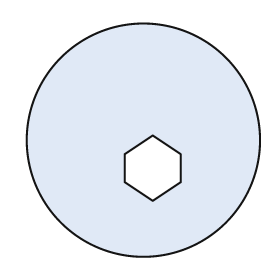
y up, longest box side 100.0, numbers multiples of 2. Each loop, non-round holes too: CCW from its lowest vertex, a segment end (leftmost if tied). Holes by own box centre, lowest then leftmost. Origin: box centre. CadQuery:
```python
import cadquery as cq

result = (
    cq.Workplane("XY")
    .moveTo(0.0, 0.0)
    .circle(50.0)
    .moveTo(4.0, -26.0)
    .lineTo(16.0, -18.0)
    .lineTo(16.0, -6.0)
    .lineTo(4.0, 2.0)
    .lineTo(-8.0, -6.0)
    .lineTo(-8.0, -18.0)
    .close()
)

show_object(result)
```